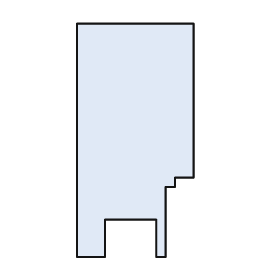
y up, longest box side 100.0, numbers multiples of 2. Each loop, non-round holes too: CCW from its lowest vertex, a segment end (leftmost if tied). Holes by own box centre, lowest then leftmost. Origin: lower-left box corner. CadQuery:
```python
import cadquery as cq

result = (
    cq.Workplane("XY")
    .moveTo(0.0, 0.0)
    .lineTo(12.0, 0.0)
    .lineTo(12.0, 16.0)
    .lineTo(34.0, 16.0)
    .lineTo(34.0, 0.0)
    .lineTo(38.0, 0.0)
    .lineTo(38.0, 30.0)
    .lineTo(42.0, 30.0)
    .lineTo(42.0, 34.0)
    .lineTo(50.0, 34.0)
    .lineTo(50.0, 100.0)
    .lineTo(0.0, 100.0)
    .close()
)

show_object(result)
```